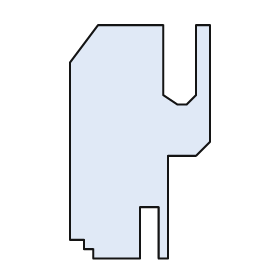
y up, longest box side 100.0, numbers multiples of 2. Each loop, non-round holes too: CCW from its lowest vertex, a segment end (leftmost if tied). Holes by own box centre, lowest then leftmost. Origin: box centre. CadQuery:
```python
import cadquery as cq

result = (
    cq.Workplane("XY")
    .moveTo(-20.0, -50.0)
    .lineTo(0.0, -50.0)
    .lineTo(0.0, -28.0)
    .lineTo(8.0, -28.0)
    .lineTo(8.0, -50.0)
    .lineTo(12.0, -50.0)
    .lineTo(12.0, -6.0)
    .lineTo(24.0, -6.0)
    .lineTo(30.0, 0.0)
    .lineTo(30.0, 50.0)
    .lineTo(24.0, 50.0)
    .lineTo(24.0, 20.0)
    .lineTo(20.0, 16.0)
    .lineTo(16.0, 16.0)
    .lineTo(10.0, 20.0)
    .lineTo(10.0, 50.0)
    .lineTo(-18.0, 50.0)
    .lineTo(-30.0, 34.0)
    .lineTo(-30.0, -42.0)
    .lineTo(-24.0, -42.0)
    .lineTo(-24.0, -46.0)
    .lineTo(-20.0, -46.0)
    .close()
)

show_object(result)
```